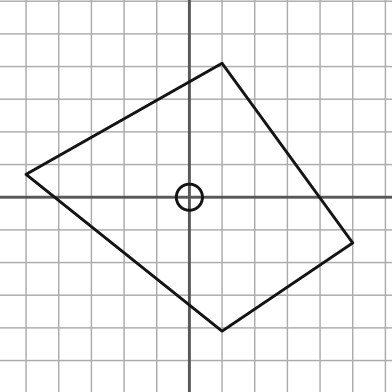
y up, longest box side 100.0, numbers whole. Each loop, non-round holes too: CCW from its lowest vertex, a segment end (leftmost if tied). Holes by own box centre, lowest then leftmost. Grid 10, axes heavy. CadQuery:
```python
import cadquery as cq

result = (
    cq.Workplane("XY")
    .moveTo(10.0, -41.0)
    .lineTo(50.0, -14.0)
    .lineTo(10.0, 41.0)
    .lineTo(-50.0, 7.0)
    .close()
    .moveTo(0.0, 0.0)
    .circle(4.0)
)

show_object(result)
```